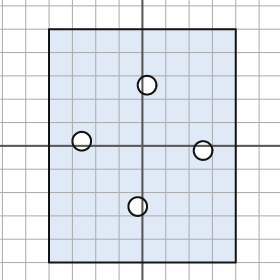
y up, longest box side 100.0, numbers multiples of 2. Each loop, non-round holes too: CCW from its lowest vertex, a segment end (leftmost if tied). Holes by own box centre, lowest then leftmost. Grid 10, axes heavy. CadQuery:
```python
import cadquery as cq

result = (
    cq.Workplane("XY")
    .moveTo(-40.0, -50.0)
    .lineTo(40.0, -50.0)
    .lineTo(40.0, 50.0)
    .lineTo(-40.0, 50.0)
    .close()
    .moveTo(-2.0, -26.0)
    .circle(4.0)
    .moveTo(26.0, -2.0)
    .circle(4.0)
    .moveTo(-26.0, 2.0)
    .circle(4.0)
    .moveTo(2.0, 26.0)
    .circle(4.0)
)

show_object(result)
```